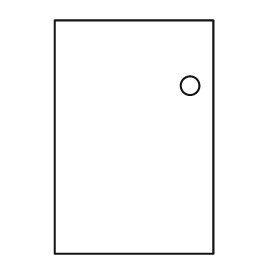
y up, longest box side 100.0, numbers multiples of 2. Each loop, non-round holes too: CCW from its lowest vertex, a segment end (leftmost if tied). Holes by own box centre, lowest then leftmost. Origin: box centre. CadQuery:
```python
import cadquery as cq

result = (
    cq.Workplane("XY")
    .moveTo(-34.0, -50.0)
    .lineTo(34.0, -50.0)
    .lineTo(34.0, 50.0)
    .lineTo(-34.0, 50.0)
    .close()
    .moveTo(24.0, 22.0)
    .circle(4.0)
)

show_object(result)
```